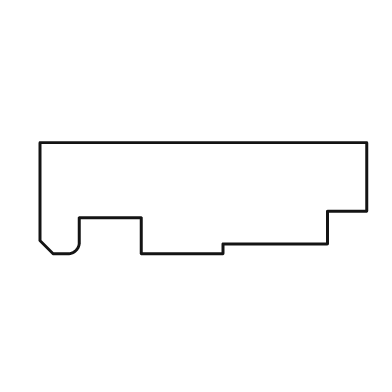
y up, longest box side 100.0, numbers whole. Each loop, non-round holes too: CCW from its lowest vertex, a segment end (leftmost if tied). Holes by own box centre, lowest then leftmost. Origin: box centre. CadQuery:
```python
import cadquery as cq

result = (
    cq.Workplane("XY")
    .moveTo(-46.0, -17.0)
    .lineTo(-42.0, -17.0)
    .threePointArc((-39.0, -16.0), (-38.0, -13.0))
    .lineTo(-38.0, -6.0)
    .lineTo(-19.0, -6.0)
    .lineTo(-19.0, -17.0)
    .lineTo(6.0, -17.0)
    .lineTo(6.0, -14.0)
    .lineTo(38.0, -14.0)
    .lineTo(38.0, -4.0)
    .lineTo(50.0, -4.0)
    .lineTo(50.0, 17.0)
    .lineTo(-50.0, 17.0)
    .lineTo(-50.0, -13.0)
    .close()
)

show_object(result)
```